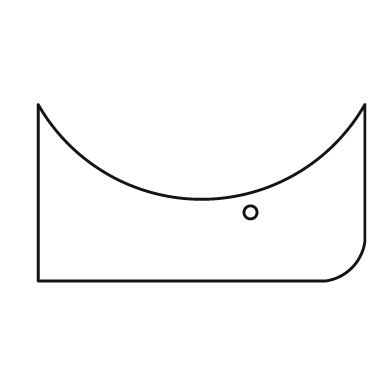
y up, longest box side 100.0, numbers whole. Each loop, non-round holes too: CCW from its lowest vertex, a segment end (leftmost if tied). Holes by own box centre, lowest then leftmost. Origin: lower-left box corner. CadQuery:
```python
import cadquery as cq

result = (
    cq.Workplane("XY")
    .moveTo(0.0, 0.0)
    .lineTo(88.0, 0.0)
    .threePointArc((96.0, 4.0), (100.0, 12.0))
    .lineTo(100.0, 54.0)
    .threePointArc((50.0, 25.0), (0.0, 54.0))
    .close()
    .moveTo(65.0, 21.0)
    .circle(2.0)
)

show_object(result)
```